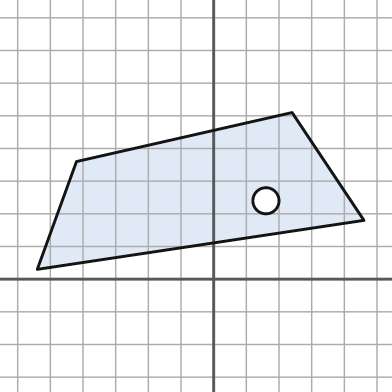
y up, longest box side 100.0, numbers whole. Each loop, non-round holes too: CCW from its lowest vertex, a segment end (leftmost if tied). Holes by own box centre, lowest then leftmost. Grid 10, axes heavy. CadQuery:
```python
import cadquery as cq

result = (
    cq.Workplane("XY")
    .moveTo(-54.0, 3.0)
    .lineTo(46.0, 18.0)
    .lineTo(24.0, 51.0)
    .lineTo(-42.0, 36.0)
    .close()
    .moveTo(16.0, 24.0)
    .circle(4.0)
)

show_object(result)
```